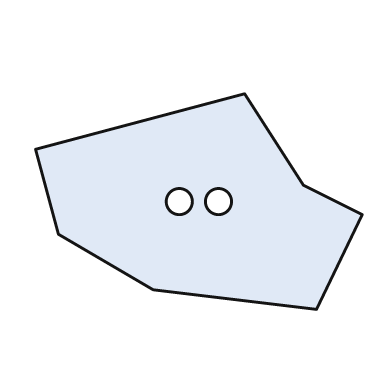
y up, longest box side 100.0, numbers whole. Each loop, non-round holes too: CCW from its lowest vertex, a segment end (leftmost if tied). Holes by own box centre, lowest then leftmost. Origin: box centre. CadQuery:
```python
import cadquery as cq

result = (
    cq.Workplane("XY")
    .moveTo(36.0, -33.0)
    .lineTo(50.0, -4.0)
    .lineTo(32.0, 5.0)
    .lineTo(14.0, 33.0)
    .lineTo(-50.0, 16.0)
    .lineTo(-43.0, -10.0)
    .lineTo(-14.0, -27.0)
    .close()
    .moveTo(-6.0, 0.0)
    .circle(4.0)
    .moveTo(6.0, 0.0)
    .circle(4.0)
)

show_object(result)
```